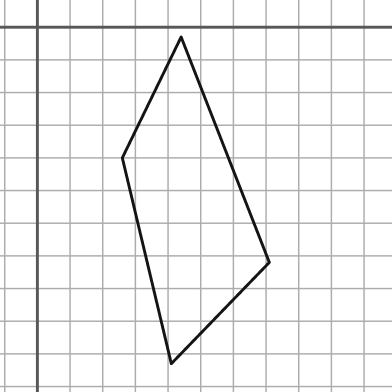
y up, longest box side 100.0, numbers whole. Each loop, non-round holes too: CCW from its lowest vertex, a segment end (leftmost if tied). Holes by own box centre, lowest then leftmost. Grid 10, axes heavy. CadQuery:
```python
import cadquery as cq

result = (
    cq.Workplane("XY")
    .moveTo(41.0, -103.0)
    .lineTo(71.0, -72.0)
    .lineTo(44.0, -3.0)
    .lineTo(26.0, -40.0)
    .close()
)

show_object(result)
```